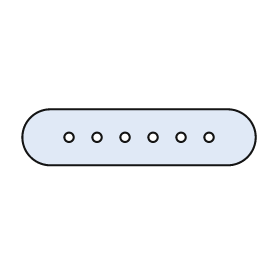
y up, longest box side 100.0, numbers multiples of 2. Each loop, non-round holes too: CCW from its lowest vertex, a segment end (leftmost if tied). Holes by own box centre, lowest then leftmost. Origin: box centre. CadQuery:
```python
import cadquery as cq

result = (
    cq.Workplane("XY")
    .moveTo(-38.0, -12.0)
    .lineTo(38.0, -12.0)
    .threePointArc((50.0, 0.0), (38.0, 12.0))
    .lineTo(-38.0, 12.0)
    .threePointArc((-50.0, 0.0), (-38.0, -12.0))
    .close()
    .moveTo(-30.0, 0.0)
    .circle(2.0)
    .moveTo(-18.0, 0.0)
    .circle(2.0)
    .moveTo(-6.0, 0.0)
    .circle(2.0)
    .moveTo(6.0, 0.0)
    .circle(2.0)
    .moveTo(18.0, 0.0)
    .circle(2.0)
    .moveTo(30.0, 0.0)
    .circle(2.0)
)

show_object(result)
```